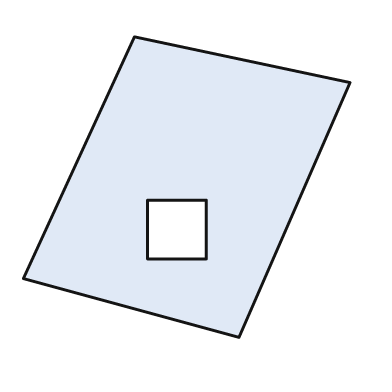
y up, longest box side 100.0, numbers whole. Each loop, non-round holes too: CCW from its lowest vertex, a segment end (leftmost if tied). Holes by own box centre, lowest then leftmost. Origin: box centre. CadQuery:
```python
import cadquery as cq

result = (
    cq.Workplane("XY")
    .moveTo(16.0, -46.0)
    .lineTo(50.0, 32.0)
    .lineTo(-16.0, 46.0)
    .lineTo(-50.0, -28.0)
    .close()
    .moveTo(-12.0, -22.0)
    .lineTo(6.0, -22.0)
    .lineTo(6.0, -4.0)
    .lineTo(-12.0, -4.0)
    .close()
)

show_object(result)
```